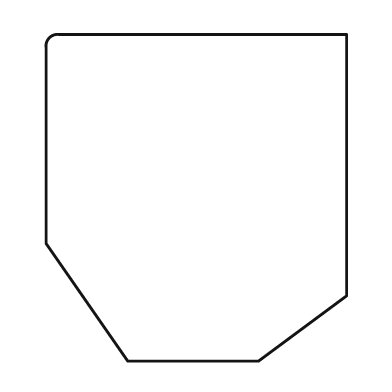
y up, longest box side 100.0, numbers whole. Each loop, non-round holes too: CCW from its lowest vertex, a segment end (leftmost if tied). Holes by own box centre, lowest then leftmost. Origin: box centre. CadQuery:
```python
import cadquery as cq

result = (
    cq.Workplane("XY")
    .moveTo(-21.0, -50.0)
    .lineTo(19.0, -50.0)
    .lineTo(46.0, -30.0)
    .lineTo(46.0, 50.0)
    .lineTo(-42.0, 50.0)
    .threePointArc((-45.0, 49.0), (-46.0, 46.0))
    .lineTo(-46.0, -14.0)
    .close()
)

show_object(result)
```